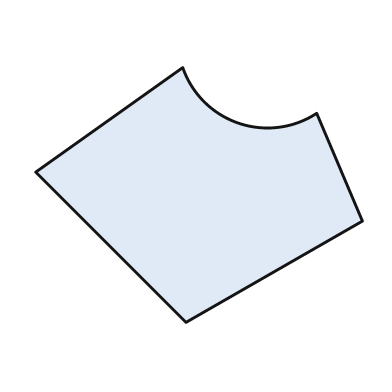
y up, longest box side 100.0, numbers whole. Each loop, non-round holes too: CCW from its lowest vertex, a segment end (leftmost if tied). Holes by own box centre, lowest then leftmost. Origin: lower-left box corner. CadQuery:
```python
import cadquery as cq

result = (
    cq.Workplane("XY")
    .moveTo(46.0, 0.0)
    .lineTo(100.0, 31.0)
    .lineTo(86.0, 64.0)
    .threePointArc((62.0, 61.0), (45.0, 78.0))
    .lineTo(0.0, 46.0)
    .close()
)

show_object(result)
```